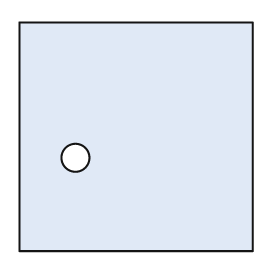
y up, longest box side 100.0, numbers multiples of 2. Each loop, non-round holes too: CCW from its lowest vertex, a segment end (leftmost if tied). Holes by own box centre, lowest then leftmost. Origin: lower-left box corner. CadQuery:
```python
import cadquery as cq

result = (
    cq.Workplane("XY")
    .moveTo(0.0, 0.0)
    .lineTo(100.0, 0.0)
    .lineTo(100.0, 98.0)
    .lineTo(0.0, 98.0)
    .close()
    .moveTo(24.0, 40.0)
    .circle(6.0)
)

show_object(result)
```